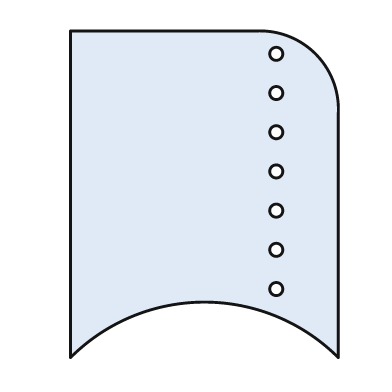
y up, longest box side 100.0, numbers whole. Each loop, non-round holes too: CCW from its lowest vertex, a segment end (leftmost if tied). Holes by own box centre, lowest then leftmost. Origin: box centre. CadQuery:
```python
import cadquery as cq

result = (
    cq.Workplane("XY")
    .moveTo(-41.0, -50.0)
    .threePointArc((0.0, -33.0), (41.0, -50.0))
    .lineTo(41.0, 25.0)
    .threePointArc((34.0, 43.0), (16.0, 50.0))
    .lineTo(-41.0, 50.0)
    .close()
    .moveTo(22.0, -29.0)
    .circle(2.0)
    .moveTo(22.0, -17.0)
    .circle(2.0)
    .moveTo(22.0, -5.0)
    .circle(2.0)
    .moveTo(22.0, 7.0)
    .circle(2.0)
    .moveTo(22.0, 19.0)
    .circle(2.0)
    .moveTo(22.0, 31.0)
    .circle(2.0)
    .moveTo(22.0, 43.0)
    .circle(2.0)
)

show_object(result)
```